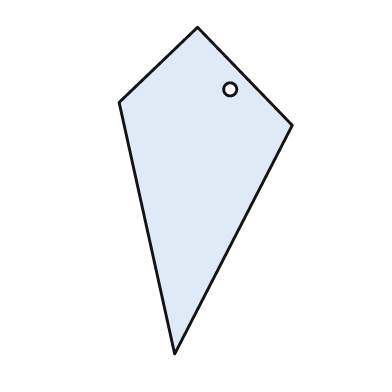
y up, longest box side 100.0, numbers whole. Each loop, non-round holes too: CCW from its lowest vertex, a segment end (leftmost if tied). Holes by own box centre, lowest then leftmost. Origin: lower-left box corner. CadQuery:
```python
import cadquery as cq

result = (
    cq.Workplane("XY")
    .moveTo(17.0, 0.0)
    .lineTo(53.0, 70.0)
    .lineTo(24.0, 100.0)
    .lineTo(0.0, 77.0)
    .close()
    .moveTo(34.0, 81.0)
    .circle(2.0)
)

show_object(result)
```